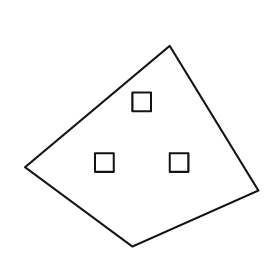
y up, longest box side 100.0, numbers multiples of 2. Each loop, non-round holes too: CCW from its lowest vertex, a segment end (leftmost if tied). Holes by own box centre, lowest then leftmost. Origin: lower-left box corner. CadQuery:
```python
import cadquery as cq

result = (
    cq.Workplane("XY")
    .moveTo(46.0, 0.0)
    .lineTo(100.0, 24.0)
    .lineTo(62.0, 86.0)
    .lineTo(0.0, 34.0)
    .close()
    .moveTo(30.0, 32.0)
    .lineTo(38.0, 32.0)
    .lineTo(38.0, 40.0)
    .lineTo(30.0, 40.0)
    .close()
    .moveTo(62.0, 32.0)
    .lineTo(70.0, 32.0)
    .lineTo(70.0, 40.0)
    .lineTo(62.0, 40.0)
    .close()
    .moveTo(46.0, 58.0)
    .lineTo(54.0, 58.0)
    .lineTo(54.0, 66.0)
    .lineTo(46.0, 66.0)
    .close()
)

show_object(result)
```